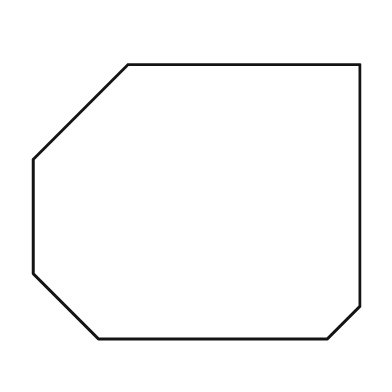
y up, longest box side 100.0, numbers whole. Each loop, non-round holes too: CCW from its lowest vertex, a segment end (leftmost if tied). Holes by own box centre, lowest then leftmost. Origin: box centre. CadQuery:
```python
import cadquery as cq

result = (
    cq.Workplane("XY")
    .moveTo(-30.0, -42.0)
    .lineTo(40.0, -42.0)
    .lineTo(50.0, -32.0)
    .lineTo(50.0, 42.0)
    .lineTo(-21.0, 42.0)
    .lineTo(-50.0, 13.0)
    .lineTo(-50.0, -22.0)
    .close()
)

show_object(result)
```